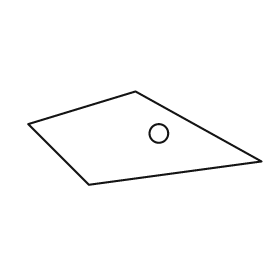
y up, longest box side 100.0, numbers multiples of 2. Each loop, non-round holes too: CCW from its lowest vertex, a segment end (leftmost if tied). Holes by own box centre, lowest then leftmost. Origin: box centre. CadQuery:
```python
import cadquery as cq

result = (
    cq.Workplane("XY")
    .moveTo(-24.0, -20.0)
    .lineTo(50.0, -10.0)
    .lineTo(-4.0, 20.0)
    .lineTo(-50.0, 6.0)
    .close()
    .moveTo(6.0, 2.0)
    .circle(4.0)
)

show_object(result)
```